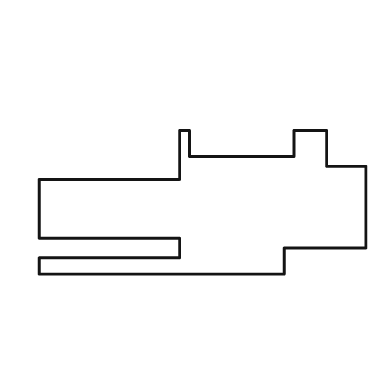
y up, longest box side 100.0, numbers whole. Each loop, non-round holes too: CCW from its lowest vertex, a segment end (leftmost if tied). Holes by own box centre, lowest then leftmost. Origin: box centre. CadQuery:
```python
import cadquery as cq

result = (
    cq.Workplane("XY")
    .moveTo(-50.0, -22.0)
    .lineTo(25.0, -22.0)
    .lineTo(25.0, -14.0)
    .lineTo(50.0, -14.0)
    .lineTo(50.0, 11.0)
    .lineTo(38.0, 11.0)
    .lineTo(38.0, 22.0)
    .lineTo(28.0, 22.0)
    .lineTo(28.0, 14.0)
    .lineTo(-4.0, 14.0)
    .lineTo(-4.0, 22.0)
    .lineTo(-7.0, 22.0)
    .lineTo(-7.0, 7.0)
    .lineTo(-50.0, 7.0)
    .lineTo(-50.0, -11.0)
    .lineTo(-7.0, -11.0)
    .lineTo(-7.0, -17.0)
    .lineTo(-50.0, -17.0)
    .close()
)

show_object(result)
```